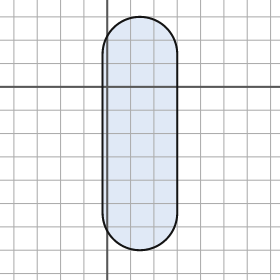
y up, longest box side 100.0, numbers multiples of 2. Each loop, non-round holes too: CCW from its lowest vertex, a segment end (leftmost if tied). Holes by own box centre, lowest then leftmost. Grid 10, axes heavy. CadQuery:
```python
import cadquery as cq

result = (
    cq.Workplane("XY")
    .moveTo(-2.0, -54.0)
    .threePointArc((14.0, -70.0), (30.0, -54.0))
    .lineTo(30.0, 14.0)
    .threePointArc((14.0, 30.0), (-2.0, 14.0))
    .close()
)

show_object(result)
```